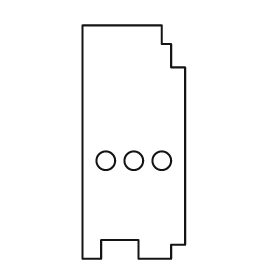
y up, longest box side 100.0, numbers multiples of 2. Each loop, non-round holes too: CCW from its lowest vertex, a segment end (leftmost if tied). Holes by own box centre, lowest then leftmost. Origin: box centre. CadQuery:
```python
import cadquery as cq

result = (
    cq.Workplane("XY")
    .moveTo(-22.0, -50.0)
    .lineTo(-14.0, -50.0)
    .lineTo(-14.0, -42.0)
    .lineTo(2.0, -42.0)
    .lineTo(2.0, -50.0)
    .lineTo(16.0, -50.0)
    .lineTo(16.0, -44.0)
    .lineTo(22.0, -44.0)
    .lineTo(22.0, 32.0)
    .lineTo(16.0, 32.0)
    .lineTo(16.0, 42.0)
    .lineTo(12.0, 42.0)
    .lineTo(12.0, 50.0)
    .lineTo(-22.0, 50.0)
    .close()
    .moveTo(-12.0, -8.0)
    .circle(4.0)
    .moveTo(0.0, -8.0)
    .circle(4.0)
    .moveTo(12.0, -8.0)
    .circle(4.0)
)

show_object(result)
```